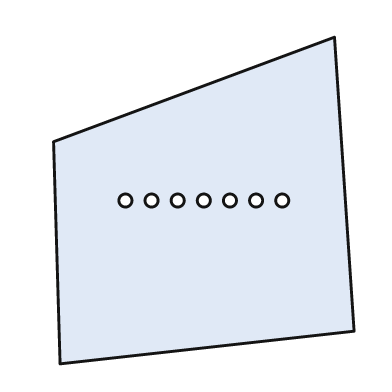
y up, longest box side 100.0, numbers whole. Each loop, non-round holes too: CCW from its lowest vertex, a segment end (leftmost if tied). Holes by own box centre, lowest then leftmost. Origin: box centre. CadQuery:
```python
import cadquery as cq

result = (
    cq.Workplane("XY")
    .moveTo(-44.0, -50.0)
    .lineTo(46.0, -40.0)
    .lineTo(40.0, 50.0)
    .lineTo(-46.0, 18.0)
    .close()
    .moveTo(-24.0, 0.0)
    .circle(2.0)
    .moveTo(-16.0, 0.0)
    .circle(2.0)
    .moveTo(-8.0, 0.0)
    .circle(2.0)
    .moveTo(0.0, 0.0)
    .circle(2.0)
    .moveTo(8.0, 0.0)
    .circle(2.0)
    .moveTo(16.0, 0.0)
    .circle(2.0)
    .moveTo(24.0, 0.0)
    .circle(2.0)
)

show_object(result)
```